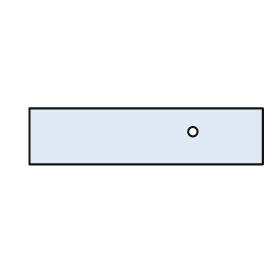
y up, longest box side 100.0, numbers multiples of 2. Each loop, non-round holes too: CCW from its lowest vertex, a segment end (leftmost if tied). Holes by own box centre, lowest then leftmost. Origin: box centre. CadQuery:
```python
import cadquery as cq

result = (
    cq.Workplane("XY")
    .moveTo(-50.0, -12.0)
    .lineTo(50.0, -12.0)
    .lineTo(50.0, 12.0)
    .lineTo(-50.0, 12.0)
    .close()
    .moveTo(20.0, 2.0)
    .circle(2.0)
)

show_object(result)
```